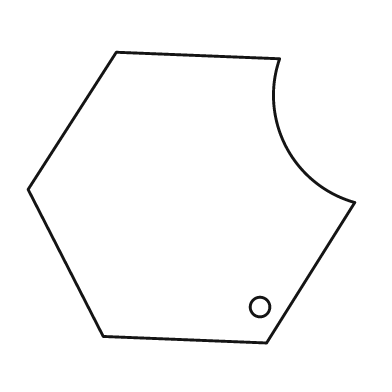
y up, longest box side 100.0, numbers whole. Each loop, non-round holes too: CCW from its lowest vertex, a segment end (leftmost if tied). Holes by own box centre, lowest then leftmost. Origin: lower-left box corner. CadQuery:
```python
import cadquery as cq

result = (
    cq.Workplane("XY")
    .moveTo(73.0, 0.0)
    .lineTo(100.0, 43.0)
    .threePointArc((79.0, 60.0), (77.0, 87.0))
    .lineTo(27.0, 89.0)
    .lineTo(0.0, 47.0)
    .lineTo(23.0, 2.0)
    .close()
    .moveTo(71.0, 11.0)
    .circle(3.0)
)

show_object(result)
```